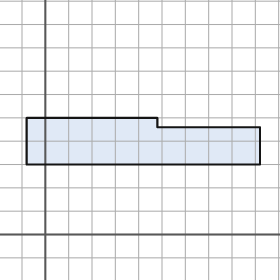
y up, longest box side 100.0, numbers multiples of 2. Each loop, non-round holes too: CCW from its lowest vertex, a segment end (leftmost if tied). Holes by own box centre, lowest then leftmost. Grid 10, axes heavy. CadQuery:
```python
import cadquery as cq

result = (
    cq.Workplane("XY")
    .moveTo(-8.0, 30.0)
    .lineTo(92.0, 30.0)
    .lineTo(92.0, 46.0)
    .lineTo(48.0, 46.0)
    .lineTo(48.0, 50.0)
    .lineTo(-8.0, 50.0)
    .close()
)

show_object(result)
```